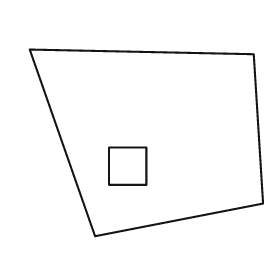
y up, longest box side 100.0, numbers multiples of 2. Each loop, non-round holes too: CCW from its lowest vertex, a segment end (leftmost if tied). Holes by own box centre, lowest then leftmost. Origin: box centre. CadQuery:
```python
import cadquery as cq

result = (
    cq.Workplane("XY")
    .moveTo(-22.0, -40.0)
    .lineTo(50.0, -26.0)
    .lineTo(46.0, 38.0)
    .lineTo(-50.0, 40.0)
    .close()
    .moveTo(-16.0, -18.0)
    .lineTo(0.0, -18.0)
    .lineTo(0.0, -2.0)
    .lineTo(-16.0, -2.0)
    .close()
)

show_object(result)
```